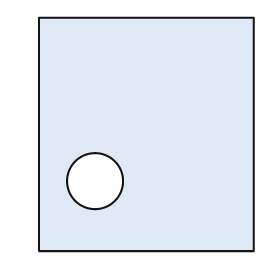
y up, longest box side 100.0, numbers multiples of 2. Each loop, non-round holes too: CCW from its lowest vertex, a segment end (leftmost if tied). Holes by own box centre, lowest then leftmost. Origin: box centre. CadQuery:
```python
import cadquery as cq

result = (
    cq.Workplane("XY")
    .moveTo(-46.0, -50.0)
    .lineTo(46.0, -50.0)
    .lineTo(46.0, 50.0)
    .lineTo(-46.0, 50.0)
    .close()
    .moveTo(-22.0, -20.0)
    .circle(12.0)
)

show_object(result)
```